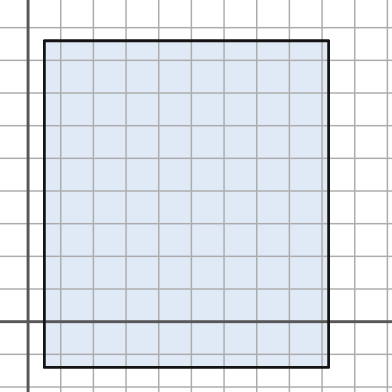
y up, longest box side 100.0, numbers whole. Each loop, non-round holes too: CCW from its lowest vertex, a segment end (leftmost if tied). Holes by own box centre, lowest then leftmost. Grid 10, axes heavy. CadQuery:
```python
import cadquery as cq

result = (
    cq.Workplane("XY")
    .moveTo(5.0, -14.0)
    .lineTo(92.0, -14.0)
    .lineTo(92.0, 86.0)
    .lineTo(5.0, 86.0)
    .close()
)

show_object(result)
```